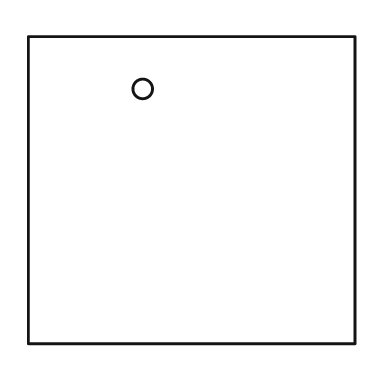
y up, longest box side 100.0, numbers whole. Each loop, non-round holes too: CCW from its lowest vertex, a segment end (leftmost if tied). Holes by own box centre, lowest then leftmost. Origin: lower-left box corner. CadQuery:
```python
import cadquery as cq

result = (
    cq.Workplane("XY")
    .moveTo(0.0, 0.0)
    .lineTo(100.0, 0.0)
    .lineTo(100.0, 94.0)
    .lineTo(0.0, 94.0)
    .close()
    .moveTo(35.0, 78.0)
    .circle(3.0)
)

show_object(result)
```